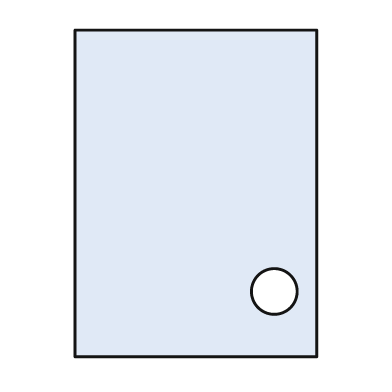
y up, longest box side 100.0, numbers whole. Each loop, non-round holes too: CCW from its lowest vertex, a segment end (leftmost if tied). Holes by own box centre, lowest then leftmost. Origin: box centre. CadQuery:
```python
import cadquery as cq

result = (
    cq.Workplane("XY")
    .moveTo(-37.0, -50.0)
    .lineTo(37.0, -50.0)
    .lineTo(37.0, 50.0)
    .lineTo(-37.0, 50.0)
    .close()
    .moveTo(24.0, -30.0)
    .circle(7.0)
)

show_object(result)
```